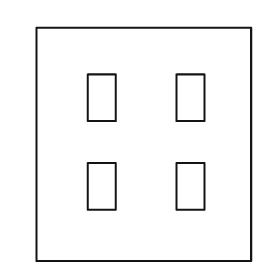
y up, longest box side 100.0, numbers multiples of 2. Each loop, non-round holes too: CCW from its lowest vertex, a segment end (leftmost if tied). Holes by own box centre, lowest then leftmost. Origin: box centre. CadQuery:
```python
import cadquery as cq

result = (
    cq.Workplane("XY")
    .moveTo(-46.0, -50.0)
    .lineTo(46.0, -50.0)
    .lineTo(46.0, 50.0)
    .lineTo(-46.0, 50.0)
    .close()
    .moveTo(-24.0, -28.0)
    .lineTo(-12.0, -28.0)
    .lineTo(-12.0, -8.0)
    .lineTo(-24.0, -8.0)
    .close()
    .moveTo(14.0, -28.0)
    .lineTo(26.0, -28.0)
    .lineTo(26.0, -8.0)
    .lineTo(14.0, -8.0)
    .close()
    .moveTo(-24.0, 10.0)
    .lineTo(-12.0, 10.0)
    .lineTo(-12.0, 30.0)
    .lineTo(-24.0, 30.0)
    .close()
    .moveTo(14.0, 10.0)
    .lineTo(26.0, 10.0)
    .lineTo(26.0, 30.0)
    .lineTo(14.0, 30.0)
    .close()
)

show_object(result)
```